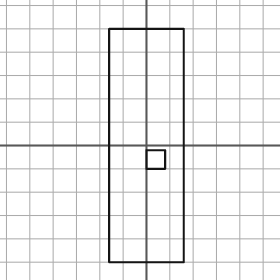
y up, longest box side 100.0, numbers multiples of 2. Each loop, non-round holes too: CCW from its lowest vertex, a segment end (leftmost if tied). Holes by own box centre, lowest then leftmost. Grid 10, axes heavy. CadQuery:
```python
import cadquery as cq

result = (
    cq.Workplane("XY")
    .moveTo(-16.0, -50.0)
    .lineTo(16.0, -50.0)
    .lineTo(16.0, 50.0)
    .lineTo(-16.0, 50.0)
    .close()
    .moveTo(0.0, -10.0)
    .lineTo(8.0, -10.0)
    .lineTo(8.0, -2.0)
    .lineTo(0.0, -2.0)
    .close()
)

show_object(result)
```